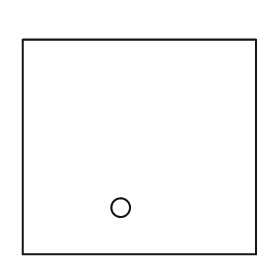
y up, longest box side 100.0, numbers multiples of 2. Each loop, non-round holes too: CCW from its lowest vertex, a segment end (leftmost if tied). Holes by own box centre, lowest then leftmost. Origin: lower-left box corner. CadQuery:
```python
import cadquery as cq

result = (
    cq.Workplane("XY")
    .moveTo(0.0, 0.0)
    .lineTo(100.0, 0.0)
    .lineTo(100.0, 92.0)
    .lineTo(0.0, 92.0)
    .close()
    .moveTo(42.0, 20.0)
    .circle(4.0)
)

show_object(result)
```